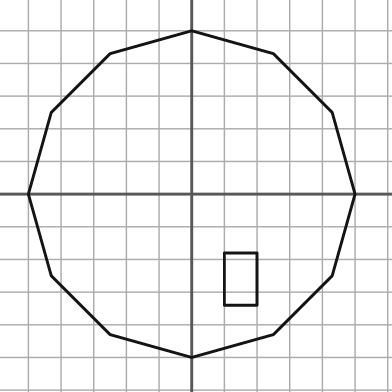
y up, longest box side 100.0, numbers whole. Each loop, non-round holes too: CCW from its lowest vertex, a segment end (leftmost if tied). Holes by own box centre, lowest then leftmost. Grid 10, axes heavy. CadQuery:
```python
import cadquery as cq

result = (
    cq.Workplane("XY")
    .moveTo(0.0, -50.0)
    .lineTo(25.0, -43.0)
    .lineTo(43.0, -25.0)
    .lineTo(50.0, 0.0)
    .lineTo(43.0, 25.0)
    .lineTo(25.0, 43.0)
    .lineTo(0.0, 50.0)
    .lineTo(-25.0, 43.0)
    .lineTo(-43.0, 25.0)
    .lineTo(-50.0, 0.0)
    .lineTo(-43.0, -25.0)
    .lineTo(-25.0, -43.0)
    .close()
    .moveTo(10.0, -34.0)
    .lineTo(20.0, -34.0)
    .lineTo(20.0, -18.0)
    .lineTo(10.0, -18.0)
    .close()
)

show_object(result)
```